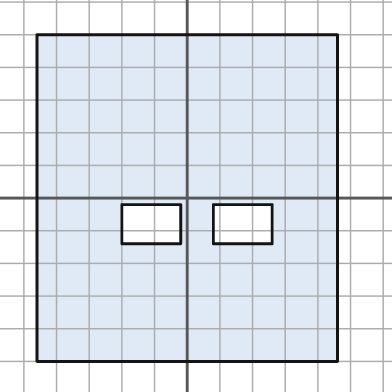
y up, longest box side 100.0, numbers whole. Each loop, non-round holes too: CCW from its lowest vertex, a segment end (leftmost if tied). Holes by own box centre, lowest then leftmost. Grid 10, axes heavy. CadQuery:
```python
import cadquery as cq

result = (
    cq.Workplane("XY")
    .moveTo(-46.0, -50.0)
    .lineTo(46.0, -50.0)
    .lineTo(46.0, 50.0)
    .lineTo(-46.0, 50.0)
    .close()
    .moveTo(-20.0, -14.0)
    .lineTo(-2.0, -14.0)
    .lineTo(-2.0, -2.0)
    .lineTo(-20.0, -2.0)
    .close()
    .moveTo(8.0, -14.0)
    .lineTo(26.0, -14.0)
    .lineTo(26.0, -2.0)
    .lineTo(8.0, -2.0)
    .close()
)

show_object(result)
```